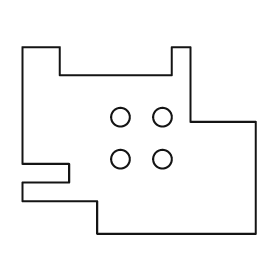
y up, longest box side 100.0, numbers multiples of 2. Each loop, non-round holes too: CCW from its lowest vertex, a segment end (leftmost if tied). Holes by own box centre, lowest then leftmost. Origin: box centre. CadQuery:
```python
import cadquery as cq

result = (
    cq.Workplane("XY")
    .moveTo(-18.0, -40.0)
    .lineTo(50.0, -40.0)
    .lineTo(50.0, 8.0)
    .lineTo(22.0, 8.0)
    .lineTo(22.0, 40.0)
    .lineTo(14.0, 40.0)
    .lineTo(14.0, 28.0)
    .lineTo(-34.0, 28.0)
    .lineTo(-34.0, 40.0)
    .lineTo(-50.0, 40.0)
    .lineTo(-50.0, -10.0)
    .lineTo(-30.0, -10.0)
    .lineTo(-30.0, -18.0)
    .lineTo(-50.0, -18.0)
    .lineTo(-50.0, -26.0)
    .lineTo(-18.0, -26.0)
    .close()
    .moveTo(-8.0, -8.0)
    .circle(4.0)
    .moveTo(10.0, -8.0)
    .circle(4.0)
    .moveTo(-8.0, 10.0)
    .circle(4.0)
    .moveTo(10.0, 10.0)
    .circle(4.0)
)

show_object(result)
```